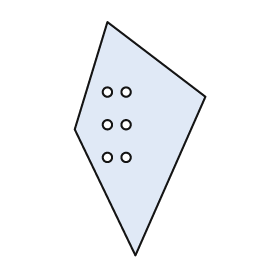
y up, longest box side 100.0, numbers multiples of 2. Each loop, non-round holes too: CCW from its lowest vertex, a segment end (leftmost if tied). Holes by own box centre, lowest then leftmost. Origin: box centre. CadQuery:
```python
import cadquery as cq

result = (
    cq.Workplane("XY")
    .moveTo(-2.0, -50.0)
    .lineTo(28.0, 18.0)
    .lineTo(-14.0, 50.0)
    .lineTo(-28.0, 4.0)
    .close()
    .moveTo(-14.0, -8.0)
    .circle(2.0)
    .moveTo(-6.0, -8.0)
    .circle(2.0)
    .moveTo(-14.0, 6.0)
    .circle(2.0)
    .moveTo(-6.0, 6.0)
    .circle(2.0)
    .moveTo(-14.0, 20.0)
    .circle(2.0)
    .moveTo(-6.0, 20.0)
    .circle(2.0)
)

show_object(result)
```